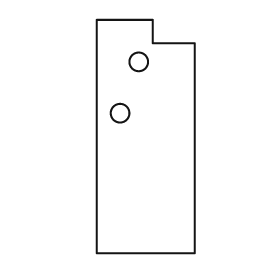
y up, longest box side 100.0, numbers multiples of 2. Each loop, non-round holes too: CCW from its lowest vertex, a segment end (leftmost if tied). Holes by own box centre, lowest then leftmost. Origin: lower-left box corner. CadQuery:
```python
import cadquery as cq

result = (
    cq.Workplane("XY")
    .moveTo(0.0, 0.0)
    .lineTo(42.0, 0.0)
    .lineTo(42.0, 90.0)
    .lineTo(24.0, 90.0)
    .lineTo(24.0, 100.0)
    .lineTo(0.0, 100.0)
    .close()
    .moveTo(10.0, 60.0)
    .circle(4.0)
    .moveTo(18.0, 82.0)
    .circle(4.0)
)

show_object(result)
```